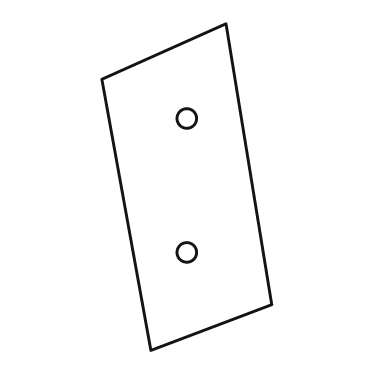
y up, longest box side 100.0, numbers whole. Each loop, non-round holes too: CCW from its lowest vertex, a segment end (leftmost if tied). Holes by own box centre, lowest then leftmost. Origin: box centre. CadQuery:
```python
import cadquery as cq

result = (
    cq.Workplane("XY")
    .moveTo(-11.0, -50.0)
    .lineTo(26.0, -36.0)
    .lineTo(12.0, 50.0)
    .lineTo(-26.0, 33.0)
    .close()
    .moveTo(0.0, -20.0)
    .circle(3.0)
    .moveTo(0.0, 21.0)
    .circle(3.0)
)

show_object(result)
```